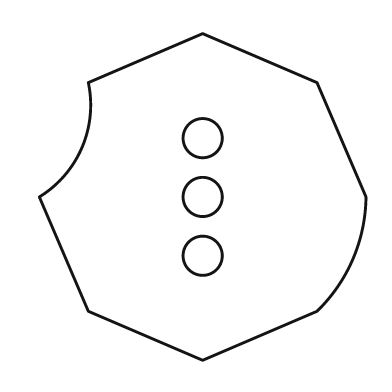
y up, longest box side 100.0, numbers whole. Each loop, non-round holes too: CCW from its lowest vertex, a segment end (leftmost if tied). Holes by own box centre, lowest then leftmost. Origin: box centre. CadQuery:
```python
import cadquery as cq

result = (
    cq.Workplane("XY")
    .moveTo(0.0, -50.0)
    .lineTo(35.0, -35.0)
    .threePointArc((46.0, -19.0), (50.0, 0.0))
    .lineTo(35.0, 35.0)
    .lineTo(0.0, 50.0)
    .lineTo(-35.0, 35.0)
    .threePointArc((-37.0, 15.0), (-50.0, 0.0))
    .lineTo(-35.0, -35.0)
    .close()
    .moveTo(0.0, -18.0)
    .circle(6.0)
    .moveTo(0.0, 0.0)
    .circle(6.0)
    .moveTo(0.0, 18.0)
    .circle(6.0)
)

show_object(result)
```